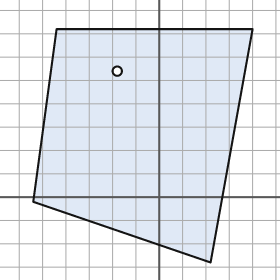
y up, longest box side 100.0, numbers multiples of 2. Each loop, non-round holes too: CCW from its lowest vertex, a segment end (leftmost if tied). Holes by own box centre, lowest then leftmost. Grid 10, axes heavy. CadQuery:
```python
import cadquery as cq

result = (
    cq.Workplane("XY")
    .moveTo(22.0, -28.0)
    .lineTo(40.0, 72.0)
    .lineTo(-44.0, 72.0)
    .lineTo(-54.0, -2.0)
    .close()
    .moveTo(-18.0, 54.0)
    .circle(2.0)
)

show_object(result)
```